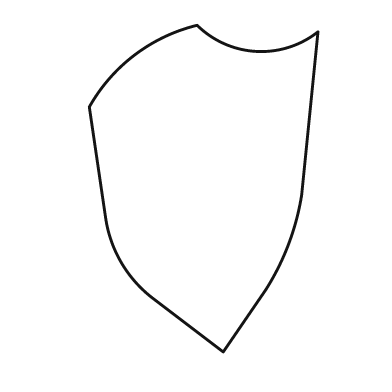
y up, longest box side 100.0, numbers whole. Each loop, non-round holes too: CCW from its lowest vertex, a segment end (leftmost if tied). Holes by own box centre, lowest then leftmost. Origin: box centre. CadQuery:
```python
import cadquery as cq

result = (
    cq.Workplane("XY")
    .moveTo(6.0, -50.0)
    .lineTo(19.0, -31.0)
    .threePointArc((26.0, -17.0), (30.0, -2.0))
    .lineTo(35.0, 48.0)
    .threePointArc((16.0, 42.0), (-2.0, 50.0))
    .threePointArc((-21.0, 41.0), (-35.0, 25.0))
    .lineTo(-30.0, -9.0)
    .threePointArc((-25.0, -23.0), (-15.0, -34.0))
    .close()
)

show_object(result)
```